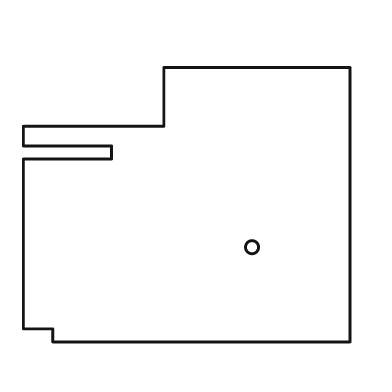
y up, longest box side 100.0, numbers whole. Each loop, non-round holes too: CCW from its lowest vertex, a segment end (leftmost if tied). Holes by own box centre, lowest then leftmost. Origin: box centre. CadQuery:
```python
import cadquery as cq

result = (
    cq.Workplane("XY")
    .moveTo(-41.0, -42.0)
    .lineTo(50.0, -42.0)
    .lineTo(50.0, 42.0)
    .lineTo(-7.0, 42.0)
    .lineTo(-7.0, 24.0)
    .lineTo(-50.0, 24.0)
    .lineTo(-50.0, 18.0)
    .lineTo(-23.0, 18.0)
    .lineTo(-23.0, 14.0)
    .lineTo(-50.0, 14.0)
    .lineTo(-50.0, -38.0)
    .lineTo(-41.0, -38.0)
    .close()
    .moveTo(20.0, -13.0)
    .circle(2.0)
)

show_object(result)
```